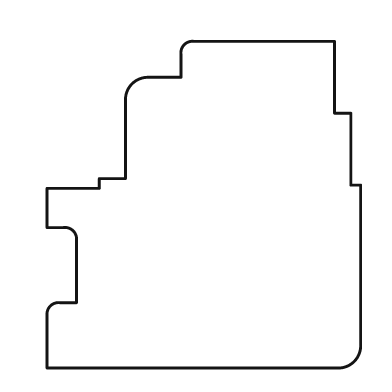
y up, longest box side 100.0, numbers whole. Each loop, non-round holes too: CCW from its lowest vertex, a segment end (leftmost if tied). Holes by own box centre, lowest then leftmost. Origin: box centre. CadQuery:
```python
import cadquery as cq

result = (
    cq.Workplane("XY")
    .moveTo(-48.0, -50.0)
    .lineTo(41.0, -50.0)
    .threePointArc((46.0, -48.0), (48.0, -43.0))
    .lineTo(48.0, 6.0)
    .lineTo(45.0, 6.0)
    .lineTo(45.0, 28.0)
    .lineTo(40.0, 28.0)
    .lineTo(40.0, 50.0)
    .lineTo(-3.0, 50.0)
    .threePointArc((-6.0, 49.0), (-7.0, 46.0))
    .lineTo(-7.0, 39.0)
    .lineTo(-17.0, 39.0)
    .threePointArc((-22.0, 37.0), (-24.0, 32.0))
    .lineTo(-24.0, 8.0)
    .lineTo(-32.0, 8.0)
    .lineTo(-32.0, 5.0)
    .lineTo(-48.0, 5.0)
    .lineTo(-48.0, -7.0)
    .lineTo(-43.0, -7.0)
    .threePointArc((-40.0, -8.0), (-39.0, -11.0))
    .lineTo(-39.0, -30.0)
    .lineTo(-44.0, -30.0)
    .threePointArc((-47.0, -31.0), (-48.0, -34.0))
    .close()
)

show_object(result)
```